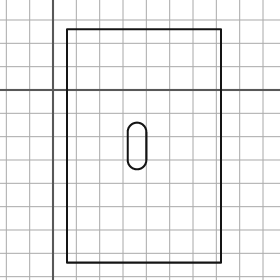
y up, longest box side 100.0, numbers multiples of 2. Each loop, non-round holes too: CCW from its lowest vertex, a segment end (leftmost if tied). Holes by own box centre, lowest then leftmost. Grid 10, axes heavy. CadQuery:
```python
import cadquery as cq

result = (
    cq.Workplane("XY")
    .moveTo(6.0, -74.0)
    .lineTo(72.0, -74.0)
    .lineTo(72.0, 26.0)
    .lineTo(6.0, 26.0)
    .close()
    .moveTo(32.0, -30.0)
    .threePointArc((36.0, -34.0), (40.0, -30.0))
    .lineTo(40.0, -18.0)
    .threePointArc((36.0, -14.0), (32.0, -18.0))
    .close()
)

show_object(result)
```